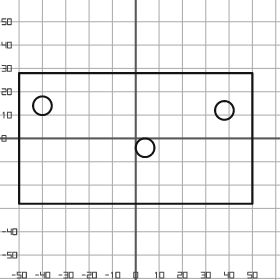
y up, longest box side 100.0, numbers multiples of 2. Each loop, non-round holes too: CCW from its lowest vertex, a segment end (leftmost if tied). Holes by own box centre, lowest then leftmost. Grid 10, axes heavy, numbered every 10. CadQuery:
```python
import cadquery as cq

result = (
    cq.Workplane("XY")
    .moveTo(-50.0, -28.0)
    .lineTo(50.0, -28.0)
    .lineTo(50.0, 28.0)
    .lineTo(-50.0, 28.0)
    .close()
    .moveTo(4.0, -4.0)
    .circle(4.0)
    .moveTo(38.0, 12.0)
    .circle(4.0)
    .moveTo(-40.0, 14.0)
    .circle(4.0)
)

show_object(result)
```